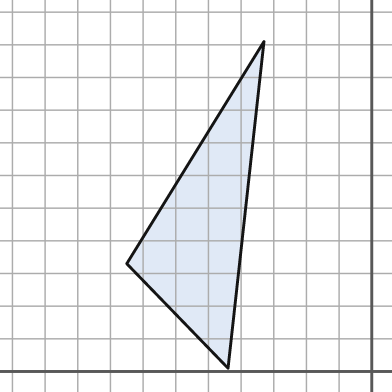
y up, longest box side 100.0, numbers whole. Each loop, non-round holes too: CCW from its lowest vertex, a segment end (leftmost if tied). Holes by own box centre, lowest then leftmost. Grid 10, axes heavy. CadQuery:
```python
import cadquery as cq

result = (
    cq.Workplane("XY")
    .moveTo(-44.0, 1.0)
    .lineTo(-33.0, 101.0)
    .lineTo(-75.0, 33.0)
    .close()
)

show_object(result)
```